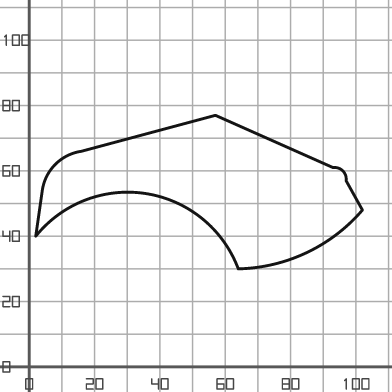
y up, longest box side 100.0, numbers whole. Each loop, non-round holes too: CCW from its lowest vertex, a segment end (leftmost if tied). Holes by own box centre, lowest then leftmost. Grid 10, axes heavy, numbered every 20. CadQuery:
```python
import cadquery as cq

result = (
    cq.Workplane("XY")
    .moveTo(64.0, 30.0)
    .threePointArc((85.0, 35.0), (102.0, 48.0))
    .lineTo(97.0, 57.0)
    .threePointArc((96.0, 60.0), (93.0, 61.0))
    .lineTo(57.0, 77.0)
    .lineTo(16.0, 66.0)
    .threePointArc((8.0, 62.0), (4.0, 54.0))
    .lineTo(2.0, 40.0)
    .threePointArc((36.0, 53.0), (64.0, 30.0))
    .close()
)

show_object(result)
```